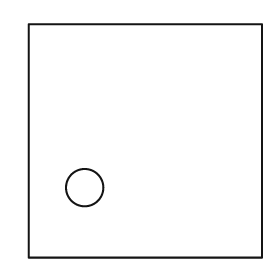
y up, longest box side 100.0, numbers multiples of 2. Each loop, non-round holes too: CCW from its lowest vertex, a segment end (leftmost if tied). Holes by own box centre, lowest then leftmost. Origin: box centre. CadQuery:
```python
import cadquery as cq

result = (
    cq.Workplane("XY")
    .moveTo(-50.0, -50.0)
    .lineTo(50.0, -50.0)
    .lineTo(50.0, 50.0)
    .lineTo(-50.0, 50.0)
    .close()
    .moveTo(-26.0, -20.0)
    .circle(8.0)
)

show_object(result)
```